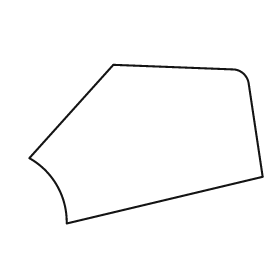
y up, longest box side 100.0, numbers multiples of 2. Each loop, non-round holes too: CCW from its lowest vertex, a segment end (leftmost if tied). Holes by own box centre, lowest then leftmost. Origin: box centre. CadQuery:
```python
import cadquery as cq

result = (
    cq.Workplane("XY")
    .moveTo(-34.0, -34.0)
    .lineTo(50.0, -14.0)
    .lineTo(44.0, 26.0)
    .threePointArc((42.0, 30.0), (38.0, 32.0))
    .lineTo(-14.0, 34.0)
    .lineTo(-50.0, -6.0)
    .threePointArc((-38.0, -18.0), (-34.0, -34.0))
    .close()
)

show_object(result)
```